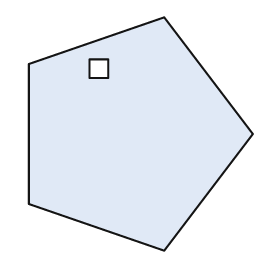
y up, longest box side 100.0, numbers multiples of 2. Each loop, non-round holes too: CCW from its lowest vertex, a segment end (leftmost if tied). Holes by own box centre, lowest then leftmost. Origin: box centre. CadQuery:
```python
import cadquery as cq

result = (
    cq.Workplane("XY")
    .moveTo(10.0, -50.0)
    .lineTo(48.0, 0.0)
    .lineTo(10.0, 50.0)
    .lineTo(-48.0, 30.0)
    .lineTo(-48.0, -30.0)
    .close()
    .moveTo(-22.0, 24.0)
    .lineTo(-14.0, 24.0)
    .lineTo(-14.0, 32.0)
    .lineTo(-22.0, 32.0)
    .close()
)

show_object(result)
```